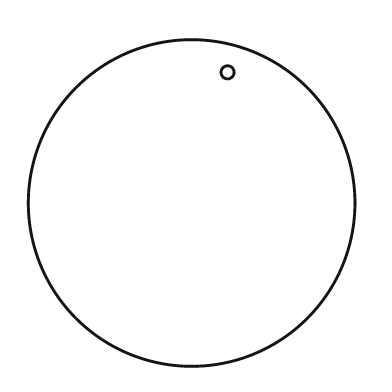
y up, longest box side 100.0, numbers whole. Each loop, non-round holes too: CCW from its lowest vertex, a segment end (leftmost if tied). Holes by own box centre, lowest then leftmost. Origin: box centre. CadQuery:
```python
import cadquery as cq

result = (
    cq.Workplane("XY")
    .moveTo(0.0, 0.0)
    .circle(50.0)
    .moveTo(11.0, 40.0)
    .circle(2.0)
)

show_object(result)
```